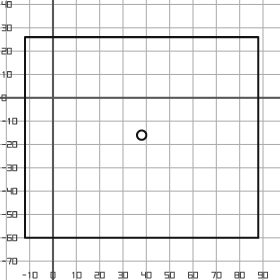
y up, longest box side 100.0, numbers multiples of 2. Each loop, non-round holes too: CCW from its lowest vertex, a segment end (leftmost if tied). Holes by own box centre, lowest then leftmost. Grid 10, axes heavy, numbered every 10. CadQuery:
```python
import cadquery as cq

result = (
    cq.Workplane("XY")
    .moveTo(-12.0, -60.0)
    .lineTo(88.0, -60.0)
    .lineTo(88.0, 26.0)
    .lineTo(-12.0, 26.0)
    .close()
    .moveTo(38.0, -16.0)
    .circle(2.0)
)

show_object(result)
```